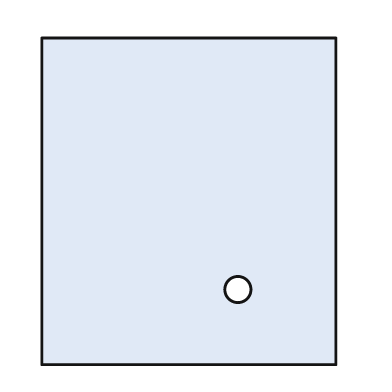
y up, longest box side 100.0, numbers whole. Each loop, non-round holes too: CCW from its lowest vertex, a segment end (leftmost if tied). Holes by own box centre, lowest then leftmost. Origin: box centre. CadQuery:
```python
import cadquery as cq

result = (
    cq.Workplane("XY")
    .moveTo(-45.0, -50.0)
    .lineTo(45.0, -50.0)
    .lineTo(45.0, 50.0)
    .lineTo(-45.0, 50.0)
    .close()
    .moveTo(15.0, -27.0)
    .circle(4.0)
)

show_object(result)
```